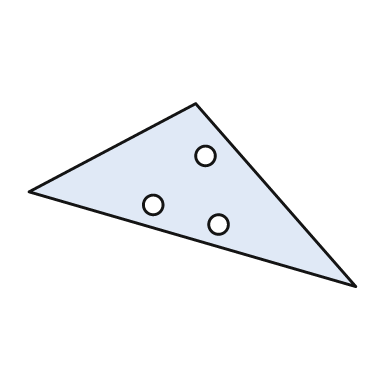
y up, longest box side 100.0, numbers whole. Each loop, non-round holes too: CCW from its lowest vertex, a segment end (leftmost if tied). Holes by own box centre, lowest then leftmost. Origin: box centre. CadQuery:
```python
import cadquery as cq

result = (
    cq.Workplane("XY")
    .moveTo(50.0, -28.0)
    .lineTo(1.0, 28.0)
    .lineTo(-50.0, 1.0)
    .close()
    .moveTo(8.0, -9.0)
    .circle(3.0)
    .moveTo(-12.0, -3.0)
    .circle(3.0)
    .moveTo(4.0, 12.0)
    .circle(3.0)
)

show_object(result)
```